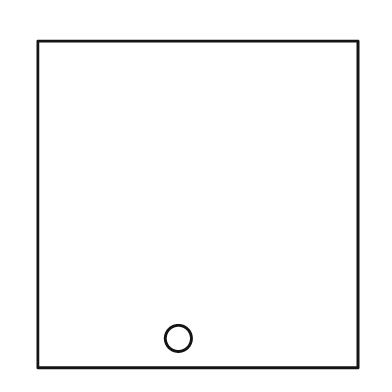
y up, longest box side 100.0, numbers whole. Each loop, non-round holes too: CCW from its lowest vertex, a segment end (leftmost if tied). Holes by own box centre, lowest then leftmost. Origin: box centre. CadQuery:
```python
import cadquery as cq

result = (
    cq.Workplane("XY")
    .moveTo(-49.0, -50.0)
    .lineTo(49.0, -50.0)
    .lineTo(49.0, 50.0)
    .lineTo(-49.0, 50.0)
    .close()
    .moveTo(-6.0, -41.0)
    .circle(4.0)
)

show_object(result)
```